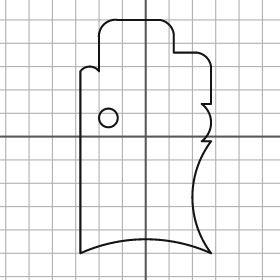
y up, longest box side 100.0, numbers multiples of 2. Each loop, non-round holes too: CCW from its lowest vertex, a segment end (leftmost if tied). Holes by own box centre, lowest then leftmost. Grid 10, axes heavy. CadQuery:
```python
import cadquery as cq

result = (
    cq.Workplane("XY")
    .moveTo(-28.0, -50.0)
    .threePointArc((0.0, -44.0), (28.0, -50.0))
    .threePointArc((20.0, -26.0), (28.0, -2.0))
    .lineTo(24.0, -2.0)
    .threePointArc((28.0, 6.0), (24.0, 14.0))
    .lineTo(28.0, 14.0)
    .lineTo(28.0, 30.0)
    .threePointArc((26.0, 34.0), (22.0, 36.0))
    .lineTo(12.0, 36.0)
    .lineTo(12.0, 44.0)
    .threePointArc((10.0, 48.0), (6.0, 50.0))
    .lineTo(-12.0, 50.0)
    .threePointArc((-18.0, 48.0), (-20.0, 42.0))
    .lineTo(-20.0, 28.0)
    .threePointArc((-24.0, 30.0), (-28.0, 28.0))
    .close()
    .moveTo(-16.0, 8.0)
    .circle(4.0)
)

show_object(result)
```